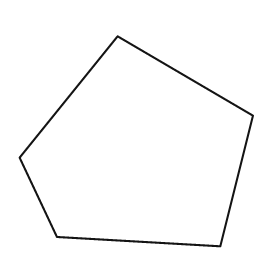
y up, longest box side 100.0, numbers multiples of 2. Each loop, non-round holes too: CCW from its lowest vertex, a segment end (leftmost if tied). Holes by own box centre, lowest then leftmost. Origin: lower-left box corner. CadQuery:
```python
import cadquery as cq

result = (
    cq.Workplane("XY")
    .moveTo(86.0, 0.0)
    .lineTo(100.0, 56.0)
    .lineTo(42.0, 90.0)
    .lineTo(0.0, 38.0)
    .lineTo(16.0, 4.0)
    .close()
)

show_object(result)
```